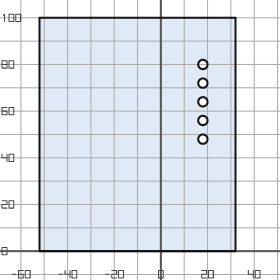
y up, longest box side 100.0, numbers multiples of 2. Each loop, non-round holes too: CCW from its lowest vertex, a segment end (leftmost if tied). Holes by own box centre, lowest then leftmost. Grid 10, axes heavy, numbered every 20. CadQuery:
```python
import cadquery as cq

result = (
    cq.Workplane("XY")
    .moveTo(-52.0, 0.0)
    .lineTo(32.0, 0.0)
    .lineTo(32.0, 100.0)
    .lineTo(-52.0, 100.0)
    .close()
    .moveTo(18.0, 48.0)
    .circle(2.0)
    .moveTo(18.0, 56.0)
    .circle(2.0)
    .moveTo(18.0, 64.0)
    .circle(2.0)
    .moveTo(18.0, 72.0)
    .circle(2.0)
    .moveTo(18.0, 80.0)
    .circle(2.0)
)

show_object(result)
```